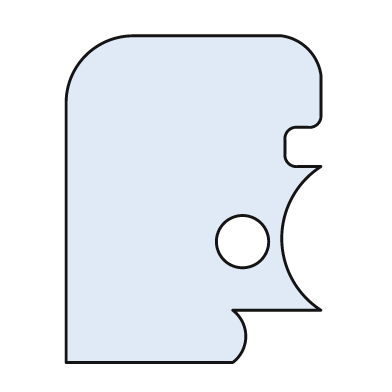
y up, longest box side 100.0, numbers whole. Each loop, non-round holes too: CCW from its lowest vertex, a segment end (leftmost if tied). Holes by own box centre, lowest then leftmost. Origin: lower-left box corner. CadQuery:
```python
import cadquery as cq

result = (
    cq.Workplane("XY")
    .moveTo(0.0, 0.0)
    .lineTo(51.0, 0.0)
    .threePointArc((55.0, 8.0), (51.0, 16.0))
    .lineTo(78.0, 16.0)
    .threePointArc((66.0, 38.0), (78.0, 60.0))
    .lineTo(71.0, 60.0)
    .threePointArc((68.0, 61.0), (67.0, 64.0))
    .lineTo(67.0, 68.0)
    .threePointArc((68.0, 71.0), (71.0, 72.0))
    .lineTo(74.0, 72.0)
    .threePointArc((77.0, 73.0), (78.0, 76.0))
    .lineTo(78.0, 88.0)
    .threePointArc((74.0, 96.0), (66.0, 100.0))
    .lineTo(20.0, 100.0)
    .threePointArc((6.0, 94.0), (0.0, 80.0))
    .close()
    .moveTo(54.0, 37.0)
    .circle(8.0)
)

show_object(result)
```